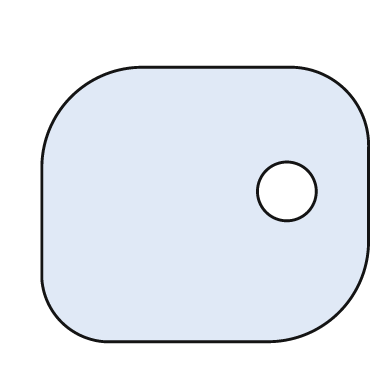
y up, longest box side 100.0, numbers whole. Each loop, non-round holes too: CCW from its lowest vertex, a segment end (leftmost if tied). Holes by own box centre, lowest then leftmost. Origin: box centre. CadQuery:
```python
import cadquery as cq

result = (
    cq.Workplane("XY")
    .moveTo(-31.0, -42.0)
    .lineTo(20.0, -42.0)
    .threePointArc((41.0, -33.0), (50.0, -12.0))
    .lineTo(50.0, 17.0)
    .threePointArc((43.0, 35.0), (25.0, 42.0))
    .lineTo(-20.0, 42.0)
    .threePointArc((-41.0, 33.0), (-50.0, 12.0))
    .lineTo(-50.0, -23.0)
    .threePointArc((-44.0, -36.0), (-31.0, -42.0))
    .close()
    .moveTo(25.0, 4.0)
    .circle(9.0)
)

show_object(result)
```